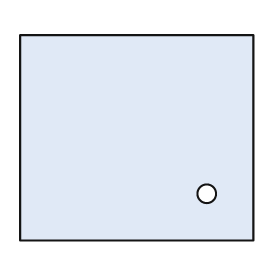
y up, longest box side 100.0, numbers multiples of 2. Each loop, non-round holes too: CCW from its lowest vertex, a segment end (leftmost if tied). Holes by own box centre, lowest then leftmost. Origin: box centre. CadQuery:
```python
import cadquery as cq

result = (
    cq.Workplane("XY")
    .moveTo(-50.0, -44.0)
    .lineTo(50.0, -44.0)
    .lineTo(50.0, 44.0)
    .lineTo(-50.0, 44.0)
    .close()
    .moveTo(30.0, -24.0)
    .circle(4.0)
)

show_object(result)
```